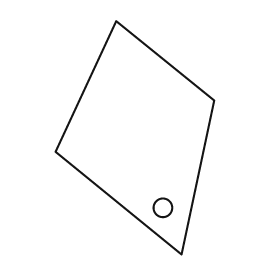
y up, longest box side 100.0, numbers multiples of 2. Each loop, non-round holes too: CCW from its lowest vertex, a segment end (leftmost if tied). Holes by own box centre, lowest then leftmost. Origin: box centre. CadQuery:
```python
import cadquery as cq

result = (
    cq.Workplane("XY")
    .moveTo(20.0, -50.0)
    .lineTo(34.0, 16.0)
    .lineTo(-8.0, 50.0)
    .lineTo(-34.0, -6.0)
    .close()
    .moveTo(12.0, -30.0)
    .circle(4.0)
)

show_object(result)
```